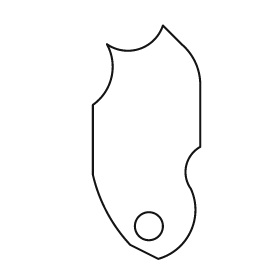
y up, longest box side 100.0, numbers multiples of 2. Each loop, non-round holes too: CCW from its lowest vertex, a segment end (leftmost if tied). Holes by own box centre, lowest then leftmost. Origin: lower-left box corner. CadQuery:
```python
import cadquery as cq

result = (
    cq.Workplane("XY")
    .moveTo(28.0, 0.0)
    .threePointArc((42.0, 12.0), (42.0, 30.0))
    .threePointArc((40.0, 40.0), (46.0, 48.0))
    .lineTo(46.0, 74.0)
    .threePointArc((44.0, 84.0), (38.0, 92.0))
    .lineTo(30.0, 100.0)
    .threePointArc((20.0, 90.0), (6.0, 92.0))
    .threePointArc((8.0, 78.0), (0.0, 66.0))
    .lineTo(0.0, 36.0)
    .threePointArc((6.0, 20.0), (16.0, 6.0))
    .close()
    .moveTo(24.0, 14.0)
    .circle(6.0)
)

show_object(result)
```